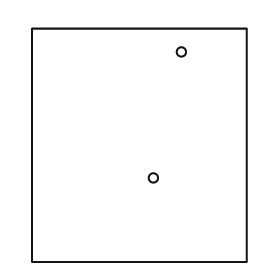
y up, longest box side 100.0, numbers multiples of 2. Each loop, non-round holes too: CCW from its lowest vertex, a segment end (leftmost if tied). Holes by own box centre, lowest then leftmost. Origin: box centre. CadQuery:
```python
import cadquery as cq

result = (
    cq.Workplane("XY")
    .moveTo(-46.0, -50.0)
    .lineTo(46.0, -50.0)
    .lineTo(46.0, 50.0)
    .lineTo(-46.0, 50.0)
    .close()
    .moveTo(6.0, -14.0)
    .circle(2.0)
    .moveTo(18.0, 40.0)
    .circle(2.0)
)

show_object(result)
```